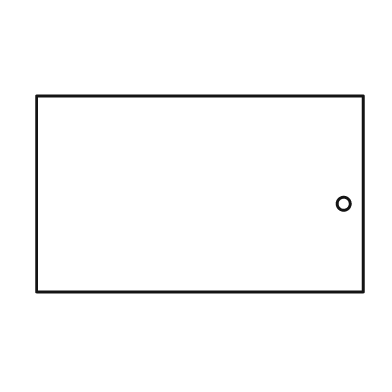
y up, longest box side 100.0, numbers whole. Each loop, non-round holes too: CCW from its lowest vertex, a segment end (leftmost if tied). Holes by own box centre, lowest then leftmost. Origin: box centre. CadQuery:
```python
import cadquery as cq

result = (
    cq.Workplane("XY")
    .moveTo(-50.0, -30.0)
    .lineTo(50.0, -30.0)
    .lineTo(50.0, 30.0)
    .lineTo(-50.0, 30.0)
    .close()
    .moveTo(44.0, -3.0)
    .circle(2.0)
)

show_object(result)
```